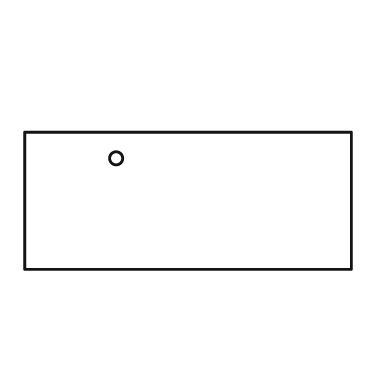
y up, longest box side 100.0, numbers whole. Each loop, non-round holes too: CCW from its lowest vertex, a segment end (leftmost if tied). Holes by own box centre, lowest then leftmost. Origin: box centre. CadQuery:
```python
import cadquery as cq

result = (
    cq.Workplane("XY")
    .moveTo(-50.0, -21.0)
    .lineTo(50.0, -21.0)
    .lineTo(50.0, 21.0)
    .lineTo(-50.0, 21.0)
    .close()
    .moveTo(-22.0, 13.0)
    .circle(2.0)
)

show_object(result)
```